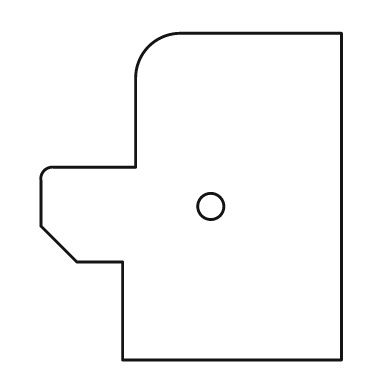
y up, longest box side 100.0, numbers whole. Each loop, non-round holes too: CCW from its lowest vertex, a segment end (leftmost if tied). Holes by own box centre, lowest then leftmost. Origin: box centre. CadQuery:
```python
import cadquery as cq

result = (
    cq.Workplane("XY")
    .moveTo(-21.0, -50.0)
    .lineTo(46.0, -50.0)
    .lineTo(46.0, 50.0)
    .lineTo(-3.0, 50.0)
    .threePointArc((-13.0, 46.0), (-17.0, 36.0))
    .lineTo(-17.0, 9.0)
    .lineTo(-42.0, 9.0)
    .threePointArc((-45.0, 8.0), (-46.0, 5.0))
    .lineTo(-46.0, -9.0)
    .lineTo(-35.0, -20.0)
    .lineTo(-21.0, -20.0)
    .close()
    .moveTo(6.0, -3.0)
    .circle(4.0)
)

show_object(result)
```